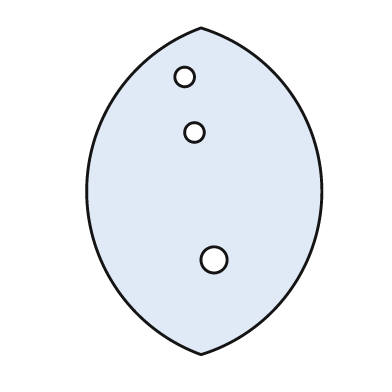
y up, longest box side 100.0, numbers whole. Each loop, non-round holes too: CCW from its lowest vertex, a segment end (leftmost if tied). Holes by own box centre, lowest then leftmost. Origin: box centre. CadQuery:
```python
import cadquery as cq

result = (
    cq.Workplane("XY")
    .moveTo(-1.0, -50.0)
    .threePointArc((36.0, 0.0), (-1.0, 50.0))
    .threePointArc((-36.0, 0.0), (-1.0, -50.0))
    .close()
    .moveTo(3.0, -21.0)
    .circle(4.0)
    .moveTo(-3.0, 18.0)
    .circle(3.0)
    .moveTo(-6.0, 35.0)
    .circle(3.0)
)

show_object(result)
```